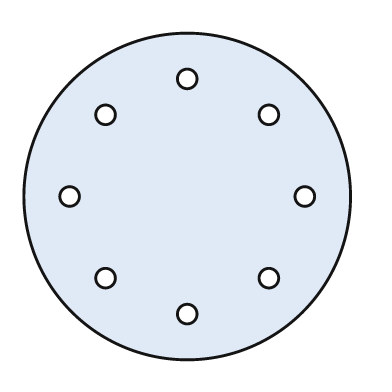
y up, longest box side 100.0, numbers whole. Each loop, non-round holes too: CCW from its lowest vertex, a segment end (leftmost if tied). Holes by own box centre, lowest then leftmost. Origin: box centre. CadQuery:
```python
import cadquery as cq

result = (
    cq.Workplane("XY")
    .moveTo(0.0, 0.0)
    .circle(50.0)
    .moveTo(0.0, -36.0)
    .circle(3.0)
    .moveTo(-25.0, -25.0)
    .circle(3.0)
    .moveTo(25.0, -25.0)
    .circle(3.0)
    .moveTo(-36.0, 0.0)
    .circle(3.0)
    .moveTo(36.0, 0.0)
    .circle(3.0)
    .moveTo(-25.0, 25.0)
    .circle(3.0)
    .moveTo(25.0, 25.0)
    .circle(3.0)
    .moveTo(0.0, 36.0)
    .circle(3.0)
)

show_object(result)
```